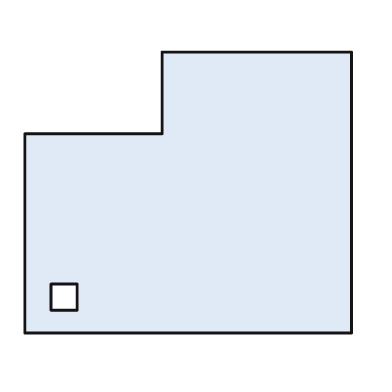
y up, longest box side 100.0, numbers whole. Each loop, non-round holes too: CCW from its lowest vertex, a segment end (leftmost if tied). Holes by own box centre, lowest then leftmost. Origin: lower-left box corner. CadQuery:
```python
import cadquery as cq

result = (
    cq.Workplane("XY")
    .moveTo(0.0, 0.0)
    .lineTo(100.0, 0.0)
    .lineTo(100.0, 86.0)
    .lineTo(42.0, 86.0)
    .lineTo(42.0, 61.0)
    .lineTo(0.0, 61.0)
    .close()
    .moveTo(8.0, 7.0)
    .lineTo(16.0, 7.0)
    .lineTo(16.0, 15.0)
    .lineTo(8.0, 15.0)
    .close()
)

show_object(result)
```